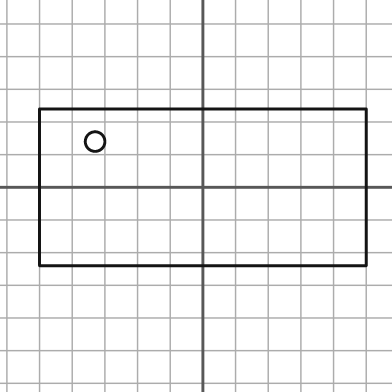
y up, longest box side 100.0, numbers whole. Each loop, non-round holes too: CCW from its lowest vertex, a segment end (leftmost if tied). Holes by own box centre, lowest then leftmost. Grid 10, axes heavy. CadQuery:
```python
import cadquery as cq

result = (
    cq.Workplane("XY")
    .moveTo(-50.0, -24.0)
    .lineTo(50.0, -24.0)
    .lineTo(50.0, 24.0)
    .lineTo(-50.0, 24.0)
    .close()
    .moveTo(-33.0, 14.0)
    .circle(3.0)
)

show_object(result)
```